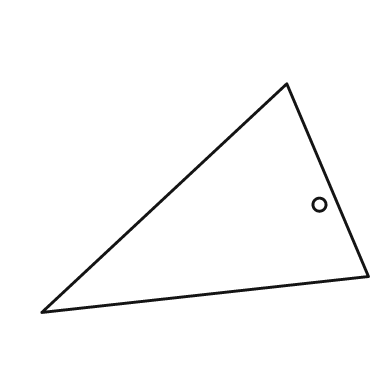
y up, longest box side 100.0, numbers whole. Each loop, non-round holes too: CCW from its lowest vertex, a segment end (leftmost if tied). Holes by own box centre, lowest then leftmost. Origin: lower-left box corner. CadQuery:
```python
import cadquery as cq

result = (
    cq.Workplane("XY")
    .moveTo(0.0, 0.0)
    .lineTo(100.0, 11.0)
    .lineTo(75.0, 70.0)
    .close()
    .moveTo(85.0, 33.0)
    .circle(2.0)
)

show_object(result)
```